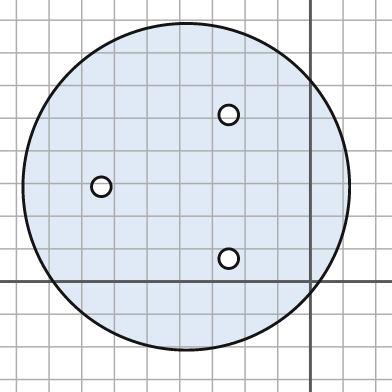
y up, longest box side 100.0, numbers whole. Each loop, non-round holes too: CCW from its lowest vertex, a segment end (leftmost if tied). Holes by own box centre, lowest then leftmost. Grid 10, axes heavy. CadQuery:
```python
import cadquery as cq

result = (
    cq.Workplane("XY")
    .moveTo(-38.0, 29.0)
    .circle(50.0)
    .moveTo(-25.0, 7.0)
    .circle(3.0)
    .moveTo(-64.0, 29.0)
    .circle(3.0)
    .moveTo(-25.0, 51.0)
    .circle(3.0)
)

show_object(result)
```